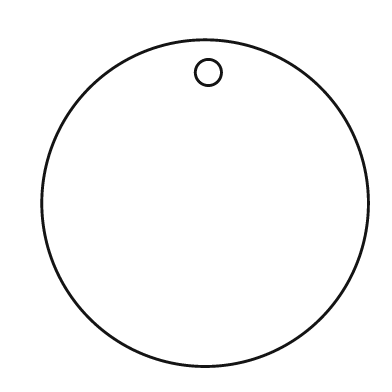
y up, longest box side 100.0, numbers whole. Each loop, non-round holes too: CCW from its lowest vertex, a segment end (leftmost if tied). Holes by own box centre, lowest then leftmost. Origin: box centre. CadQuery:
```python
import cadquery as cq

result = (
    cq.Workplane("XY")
    .moveTo(0.0, 0.0)
    .circle(50.0)
    .moveTo(1.0, 40.0)
    .circle(4.0)
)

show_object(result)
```